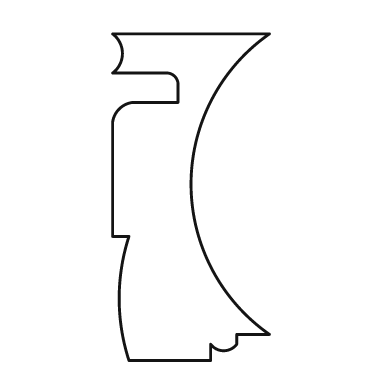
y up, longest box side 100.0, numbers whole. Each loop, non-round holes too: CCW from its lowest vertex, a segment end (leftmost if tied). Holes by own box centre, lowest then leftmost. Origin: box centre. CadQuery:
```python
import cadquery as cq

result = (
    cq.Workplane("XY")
    .moveTo(-19.0, -50.0)
    .lineTo(6.0, -50.0)
    .lineTo(6.0, -45.0)
    .threePointArc((10.0, -47.0), (14.0, -45.0))
    .lineTo(14.0, -42.0)
    .lineTo(24.0, -42.0)
    .threePointArc((0.0, 4.0), (24.0, 50.0))
    .lineTo(-24.0, 50.0)
    .threePointArc((-21.0, 44.0), (-24.0, 38.0))
    .lineTo(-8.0, 38.0)
    .threePointArc((-5.0, 37.0), (-4.0, 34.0))
    .lineTo(-4.0, 29.0)
    .lineTo(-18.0, 29.0)
    .threePointArc((-22.0, 27.0), (-24.0, 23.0))
    .lineTo(-24.0, -12.0)
    .lineTo(-19.0, -12.0)
    .threePointArc((-22.0, -31.0), (-19.0, -50.0))
    .close()
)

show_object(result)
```